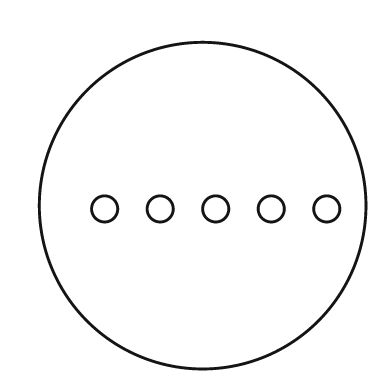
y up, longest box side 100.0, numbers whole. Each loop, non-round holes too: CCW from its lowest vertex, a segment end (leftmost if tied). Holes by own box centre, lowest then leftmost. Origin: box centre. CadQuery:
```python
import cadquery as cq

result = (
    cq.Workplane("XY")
    .moveTo(0.0, 0.0)
    .circle(50.0)
    .moveTo(-30.0, -1.0)
    .circle(4.0)
    .moveTo(-13.0, -1.0)
    .circle(4.0)
    .moveTo(4.0, -1.0)
    .circle(4.0)
    .moveTo(21.0, -1.0)
    .circle(4.0)
    .moveTo(38.0, -1.0)
    .circle(4.0)
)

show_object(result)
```